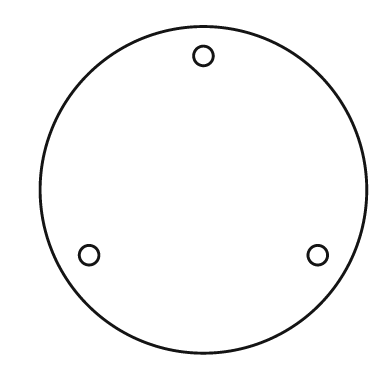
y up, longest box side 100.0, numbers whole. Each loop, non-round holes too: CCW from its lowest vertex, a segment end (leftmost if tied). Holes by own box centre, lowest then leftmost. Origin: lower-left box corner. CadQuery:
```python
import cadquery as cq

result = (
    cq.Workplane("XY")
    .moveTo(50.0, 50.0)
    .circle(50.0)
    .moveTo(15.0, 30.0)
    .circle(3.0)
    .moveTo(85.0, 30.0)
    .circle(3.0)
    .moveTo(50.0, 91.0)
    .circle(3.0)
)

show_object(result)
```